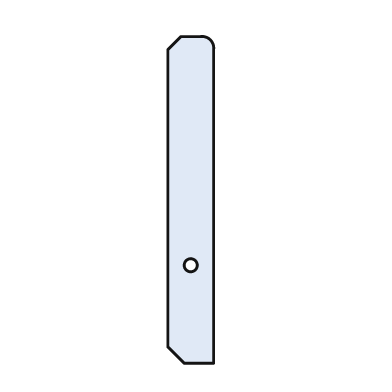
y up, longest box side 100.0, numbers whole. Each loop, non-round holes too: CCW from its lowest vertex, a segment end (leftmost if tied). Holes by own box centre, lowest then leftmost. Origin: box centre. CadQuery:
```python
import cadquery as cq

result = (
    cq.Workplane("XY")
    .moveTo(-2.0, -50.0)
    .lineTo(7.0, -50.0)
    .lineTo(7.0, 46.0)
    .threePointArc((6.0, 49.0), (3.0, 50.0))
    .lineTo(-3.0, 50.0)
    .lineTo(-7.0, 46.0)
    .lineTo(-7.0, -45.0)
    .close()
    .moveTo(0.0, -20.0)
    .circle(2.0)
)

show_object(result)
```